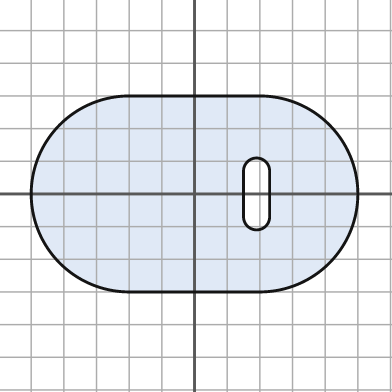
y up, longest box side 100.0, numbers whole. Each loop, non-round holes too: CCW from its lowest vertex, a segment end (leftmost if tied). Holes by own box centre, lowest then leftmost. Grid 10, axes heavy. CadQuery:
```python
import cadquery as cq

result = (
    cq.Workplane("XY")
    .moveTo(-20.0, -30.0)
    .lineTo(20.0, -30.0)
    .threePointArc((50.0, 0.0), (20.0, 30.0))
    .lineTo(-20.0, 30.0)
    .threePointArc((-50.0, 0.0), (-20.0, -30.0))
    .close()
    .moveTo(15.0, -7.0)
    .threePointArc((19.0, -11.0), (23.0, -7.0))
    .lineTo(23.0, 7.0)
    .threePointArc((19.0, 11.0), (15.0, 7.0))
    .close()
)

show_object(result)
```